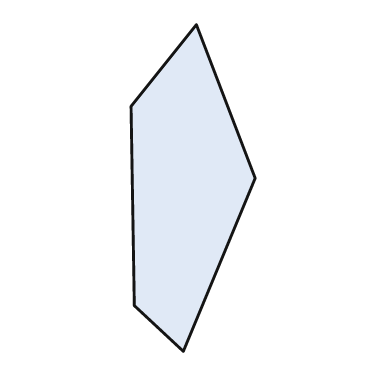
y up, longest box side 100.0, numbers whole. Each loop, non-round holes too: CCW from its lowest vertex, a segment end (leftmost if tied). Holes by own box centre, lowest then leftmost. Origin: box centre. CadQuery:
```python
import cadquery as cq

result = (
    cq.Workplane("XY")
    .moveTo(-3.0, -50.0)
    .lineTo(19.0, 3.0)
    .lineTo(1.0, 50.0)
    .lineTo(-19.0, 25.0)
    .lineTo(-18.0, -36.0)
    .close()
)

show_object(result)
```